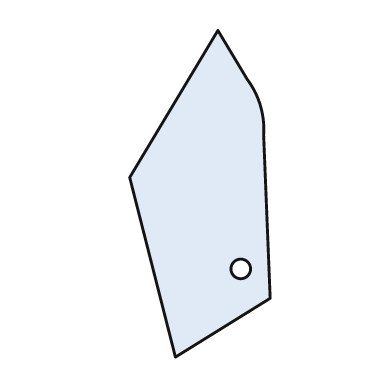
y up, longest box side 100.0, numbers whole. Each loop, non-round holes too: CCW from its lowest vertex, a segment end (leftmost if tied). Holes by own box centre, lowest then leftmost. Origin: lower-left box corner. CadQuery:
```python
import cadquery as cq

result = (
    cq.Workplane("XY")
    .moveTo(14.0, 0.0)
    .lineTo(43.0, 18.0)
    .lineTo(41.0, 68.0)
    .threePointArc((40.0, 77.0), (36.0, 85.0))
    .lineTo(27.0, 100.0)
    .lineTo(0.0, 55.0)
    .close()
    .moveTo(34.0, 27.0)
    .circle(3.0)
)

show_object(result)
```